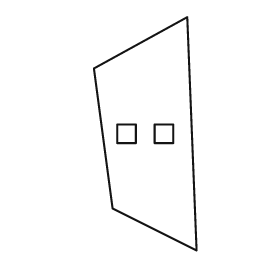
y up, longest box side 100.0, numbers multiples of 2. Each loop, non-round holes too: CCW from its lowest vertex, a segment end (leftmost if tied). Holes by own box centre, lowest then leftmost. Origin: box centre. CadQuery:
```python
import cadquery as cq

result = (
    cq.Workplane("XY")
    .moveTo(22.0, -50.0)
    .lineTo(18.0, 50.0)
    .lineTo(-22.0, 28.0)
    .lineTo(-14.0, -32.0)
    .close()
    .moveTo(-12.0, -4.0)
    .lineTo(-4.0, -4.0)
    .lineTo(-4.0, 4.0)
    .lineTo(-12.0, 4.0)
    .close()
    .moveTo(4.0, -4.0)
    .lineTo(12.0, -4.0)
    .lineTo(12.0, 4.0)
    .lineTo(4.0, 4.0)
    .close()
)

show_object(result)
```